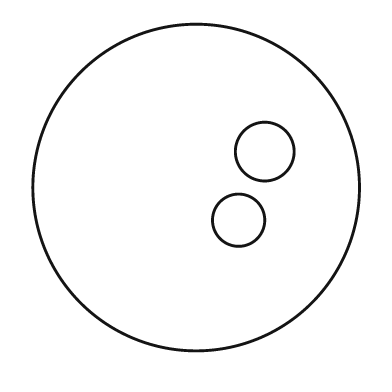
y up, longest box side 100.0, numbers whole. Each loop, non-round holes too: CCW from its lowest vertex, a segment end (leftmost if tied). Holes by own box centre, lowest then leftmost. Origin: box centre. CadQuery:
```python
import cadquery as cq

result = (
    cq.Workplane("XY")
    .moveTo(0.0, 0.0)
    .circle(50.0)
    .moveTo(13.0, -10.0)
    .circle(8.0)
    .moveTo(21.0, 11.0)
    .circle(9.0)
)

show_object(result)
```